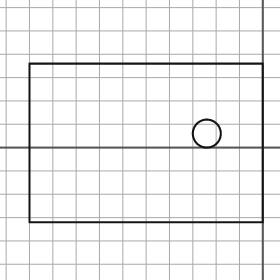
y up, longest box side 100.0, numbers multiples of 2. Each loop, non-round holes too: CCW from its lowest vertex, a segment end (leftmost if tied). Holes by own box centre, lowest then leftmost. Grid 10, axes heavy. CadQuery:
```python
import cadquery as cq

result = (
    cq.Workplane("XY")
    .moveTo(-100.0, -32.0)
    .lineTo(0.0, -32.0)
    .lineTo(0.0, 36.0)
    .lineTo(-100.0, 36.0)
    .close()
    .moveTo(-24.0, 6.0)
    .circle(6.0)
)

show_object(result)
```